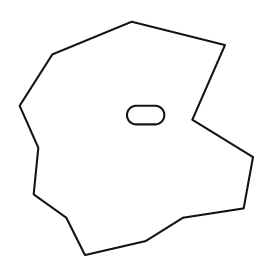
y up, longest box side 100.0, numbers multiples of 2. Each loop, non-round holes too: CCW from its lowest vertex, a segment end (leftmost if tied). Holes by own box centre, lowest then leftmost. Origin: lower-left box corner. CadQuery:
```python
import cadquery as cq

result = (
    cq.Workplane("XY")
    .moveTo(28.0, 0.0)
    .lineTo(54.0, 6.0)
    .lineTo(70.0, 16.0)
    .lineTo(96.0, 20.0)
    .lineTo(100.0, 42.0)
    .lineTo(74.0, 58.0)
    .lineTo(88.0, 90.0)
    .lineTo(48.0, 100.0)
    .lineTo(14.0, 86.0)
    .lineTo(0.0, 64.0)
    .lineTo(8.0, 46.0)
    .lineTo(6.0, 26.0)
    .lineTo(20.0, 16.0)
    .close()
    .moveTo(50.0, 56.0)
    .lineTo(58.0, 56.0)
    .threePointArc((62.0, 60.0), (58.0, 64.0))
    .lineTo(50.0, 64.0)
    .threePointArc((46.0, 60.0), (50.0, 56.0))
    .close()
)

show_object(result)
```